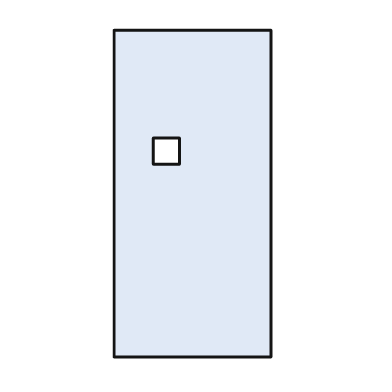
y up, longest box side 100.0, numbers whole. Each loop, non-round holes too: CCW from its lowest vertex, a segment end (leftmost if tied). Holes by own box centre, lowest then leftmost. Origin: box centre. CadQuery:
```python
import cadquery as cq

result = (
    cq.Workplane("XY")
    .moveTo(-24.0, -50.0)
    .lineTo(24.0, -50.0)
    .lineTo(24.0, 50.0)
    .lineTo(-24.0, 50.0)
    .close()
    .moveTo(-12.0, 9.0)
    .lineTo(-4.0, 9.0)
    .lineTo(-4.0, 17.0)
    .lineTo(-12.0, 17.0)
    .close()
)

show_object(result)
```